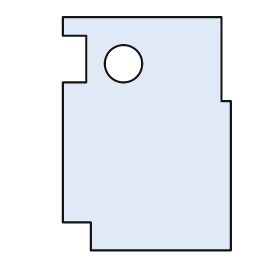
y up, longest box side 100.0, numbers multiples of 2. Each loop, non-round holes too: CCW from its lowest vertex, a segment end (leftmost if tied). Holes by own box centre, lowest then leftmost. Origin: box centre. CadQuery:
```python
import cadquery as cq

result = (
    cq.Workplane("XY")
    .moveTo(-24.0, -50.0)
    .lineTo(36.0, -50.0)
    .lineTo(36.0, 14.0)
    .lineTo(32.0, 14.0)
    .lineTo(32.0, 50.0)
    .lineTo(-36.0, 50.0)
    .lineTo(-36.0, 42.0)
    .lineTo(-26.0, 42.0)
    .lineTo(-26.0, 22.0)
    .lineTo(-36.0, 22.0)
    .lineTo(-36.0, -38.0)
    .lineTo(-24.0, -38.0)
    .close()
    .moveTo(-10.0, 30.0)
    .circle(8.0)
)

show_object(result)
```